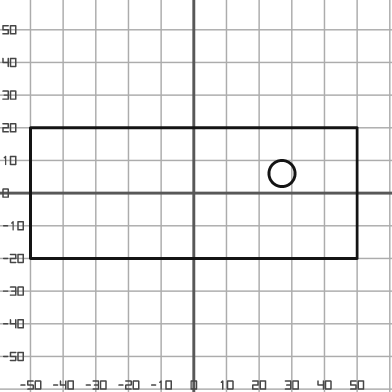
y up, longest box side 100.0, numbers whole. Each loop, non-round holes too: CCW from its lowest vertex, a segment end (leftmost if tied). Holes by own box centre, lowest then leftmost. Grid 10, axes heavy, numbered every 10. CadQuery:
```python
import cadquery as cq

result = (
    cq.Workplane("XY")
    .moveTo(-50.0, -20.0)
    .lineTo(50.0, -20.0)
    .lineTo(50.0, 20.0)
    .lineTo(-50.0, 20.0)
    .close()
    .moveTo(27.0, 6.0)
    .circle(4.0)
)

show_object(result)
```